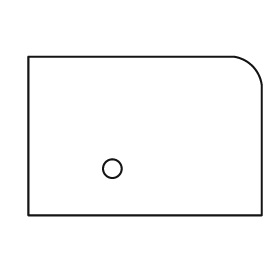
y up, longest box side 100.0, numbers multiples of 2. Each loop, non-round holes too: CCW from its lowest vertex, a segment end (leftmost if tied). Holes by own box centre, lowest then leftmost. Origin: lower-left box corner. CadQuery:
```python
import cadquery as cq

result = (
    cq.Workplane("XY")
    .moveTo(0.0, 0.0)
    .lineTo(100.0, 0.0)
    .lineTo(100.0, 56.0)
    .threePointArc((96.0, 64.0), (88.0, 68.0))
    .lineTo(0.0, 68.0)
    .close()
    .moveTo(36.0, 20.0)
    .circle(4.0)
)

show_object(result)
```